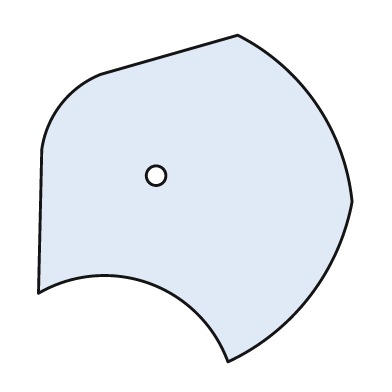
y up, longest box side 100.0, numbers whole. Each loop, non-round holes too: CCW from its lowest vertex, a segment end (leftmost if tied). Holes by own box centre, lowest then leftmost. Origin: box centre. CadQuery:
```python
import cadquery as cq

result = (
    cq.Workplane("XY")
    .moveTo(10.0, -50.0)
    .threePointArc((35.0, -30.0), (48.0, -1.0))
    .threePointArc((37.0, 29.0), (13.0, 50.0))
    .lineTo(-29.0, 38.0)
    .threePointArc((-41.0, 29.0), (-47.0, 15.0))
    .lineTo(-48.0, -29.0)
    .threePointArc((-14.0, -26.0), (10.0, -50.0))
    .close()
    .moveTo(-12.0, 7.0)
    .circle(3.0)
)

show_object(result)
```